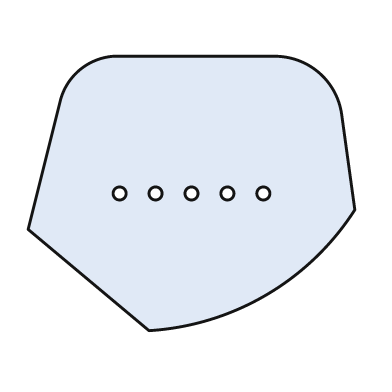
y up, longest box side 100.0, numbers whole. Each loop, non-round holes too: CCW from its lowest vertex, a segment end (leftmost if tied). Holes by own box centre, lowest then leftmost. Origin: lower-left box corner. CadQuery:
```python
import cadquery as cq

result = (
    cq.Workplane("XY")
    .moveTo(37.0, 0.0)
    .threePointArc((73.0, 11.0), (100.0, 37.0))
    .lineTo(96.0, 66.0)
    .threePointArc((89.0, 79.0), (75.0, 84.0))
    .lineTo(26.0, 84.0)
    .threePointArc((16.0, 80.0), (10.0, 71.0))
    .lineTo(0.0, 31.0)
    .close()
    .moveTo(28.0, 42.0)
    .circle(2.0)
    .moveTo(39.0, 42.0)
    .circle(2.0)
    .moveTo(50.0, 42.0)
    .circle(2.0)
    .moveTo(61.0, 42.0)
    .circle(2.0)
    .moveTo(72.0, 42.0)
    .circle(2.0)
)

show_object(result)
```